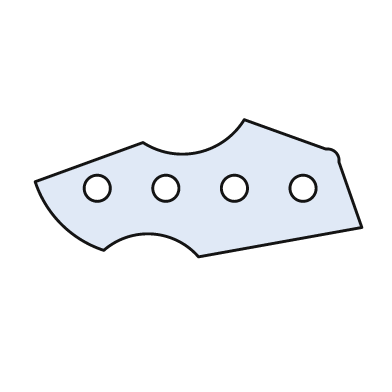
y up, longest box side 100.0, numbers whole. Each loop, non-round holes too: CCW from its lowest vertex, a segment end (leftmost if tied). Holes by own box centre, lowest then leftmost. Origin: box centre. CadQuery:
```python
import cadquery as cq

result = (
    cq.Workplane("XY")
    .moveTo(0.0, -21.0)
    .lineTo(50.0, -12.0)
    .lineTo(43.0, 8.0)
    .threePointArc((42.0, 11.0), (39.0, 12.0))
    .lineTo(14.0, 21.0)
    .threePointArc((0.0, 11.0), (-17.0, 14.0))
    .lineTo(-50.0, 2.0)
    .threePointArc((-42.0, -11.0), (-29.0, -19.0))
    .threePointArc((-14.0, -14.0), (0.0, -21.0))
    .close()
    .moveTo(-31.0, 0.0)
    .circle(4.0)
    .moveTo(-10.0, 0.0)
    .circle(4.0)
    .moveTo(11.0, 0.0)
    .circle(4.0)
    .moveTo(32.0, 0.0)
    .circle(4.0)
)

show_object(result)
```